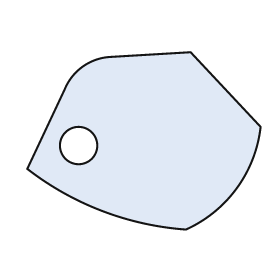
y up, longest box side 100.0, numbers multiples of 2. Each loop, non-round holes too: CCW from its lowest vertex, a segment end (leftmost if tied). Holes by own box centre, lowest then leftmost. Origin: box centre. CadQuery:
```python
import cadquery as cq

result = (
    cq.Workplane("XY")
    .moveTo(18.0, -38.0)
    .threePointArc((40.0, -20.0), (50.0, 6.0))
    .lineTo(20.0, 38.0)
    .lineTo(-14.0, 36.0)
    .threePointArc((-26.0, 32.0), (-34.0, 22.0))
    .lineTo(-50.0, -12.0)
    .threePointArc((-18.0, -30.0), (18.0, -38.0))
    .close()
    .moveTo(-28.0, -2.0)
    .circle(8.0)
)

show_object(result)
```